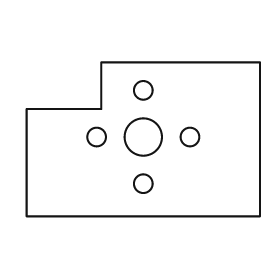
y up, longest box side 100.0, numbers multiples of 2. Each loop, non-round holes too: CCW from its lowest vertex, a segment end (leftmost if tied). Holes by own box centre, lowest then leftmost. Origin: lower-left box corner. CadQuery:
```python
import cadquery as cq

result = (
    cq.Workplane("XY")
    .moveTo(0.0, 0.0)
    .lineTo(100.0, 0.0)
    .lineTo(100.0, 66.0)
    .lineTo(32.0, 66.0)
    .lineTo(32.0, 46.0)
    .lineTo(0.0, 46.0)
    .close()
    .moveTo(50.0, 14.0)
    .circle(4.0)
    .moveTo(30.0, 34.0)
    .circle(4.0)
    .moveTo(50.0, 34.0)
    .circle(8.0)
    .moveTo(70.0, 34.0)
    .circle(4.0)
    .moveTo(50.0, 54.0)
    .circle(4.0)
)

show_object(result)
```